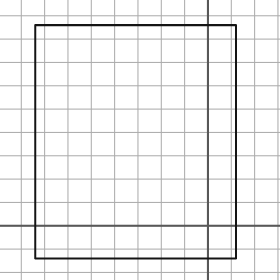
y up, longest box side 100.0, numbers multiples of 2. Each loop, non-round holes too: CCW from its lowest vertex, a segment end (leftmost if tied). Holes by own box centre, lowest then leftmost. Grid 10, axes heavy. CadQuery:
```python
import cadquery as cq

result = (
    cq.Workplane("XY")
    .moveTo(-74.0, -14.0)
    .lineTo(12.0, -14.0)
    .lineTo(12.0, 86.0)
    .lineTo(-74.0, 86.0)
    .close()
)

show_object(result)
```